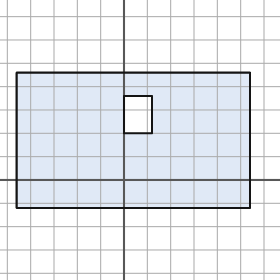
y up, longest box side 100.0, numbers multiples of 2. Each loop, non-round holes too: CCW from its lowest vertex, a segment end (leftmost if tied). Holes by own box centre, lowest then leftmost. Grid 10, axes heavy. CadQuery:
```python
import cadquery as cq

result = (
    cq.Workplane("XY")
    .moveTo(-46.0, -12.0)
    .lineTo(54.0, -12.0)
    .lineTo(54.0, 46.0)
    .lineTo(-46.0, 46.0)
    .close()
    .moveTo(0.0, 20.0)
    .lineTo(12.0, 20.0)
    .lineTo(12.0, 36.0)
    .lineTo(0.0, 36.0)
    .close()
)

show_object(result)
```